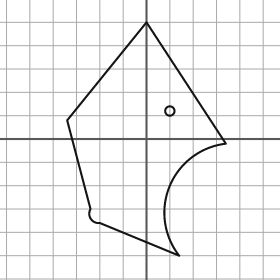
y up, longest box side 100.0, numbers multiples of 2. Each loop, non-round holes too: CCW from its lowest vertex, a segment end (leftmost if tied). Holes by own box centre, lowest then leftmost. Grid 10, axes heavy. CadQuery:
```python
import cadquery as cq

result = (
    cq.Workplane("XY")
    .moveTo(14.0, -50.0)
    .threePointArc((10.0, -20.0), (34.0, -2.0))
    .lineTo(0.0, 50.0)
    .lineTo(-34.0, 8.0)
    .lineTo(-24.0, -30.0)
    .threePointArc((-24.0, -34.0), (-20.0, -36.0))
    .close()
    .moveTo(10.0, 12.0)
    .circle(2.0)
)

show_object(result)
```